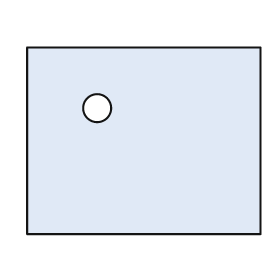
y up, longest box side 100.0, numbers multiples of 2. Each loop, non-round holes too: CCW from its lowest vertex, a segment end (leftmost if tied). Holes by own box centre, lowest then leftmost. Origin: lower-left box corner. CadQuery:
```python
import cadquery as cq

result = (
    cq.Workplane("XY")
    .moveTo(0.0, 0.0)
    .lineTo(100.0, 0.0)
    .lineTo(100.0, 80.0)
    .lineTo(0.0, 80.0)
    .close()
    .moveTo(30.0, 54.0)
    .circle(6.0)
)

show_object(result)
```